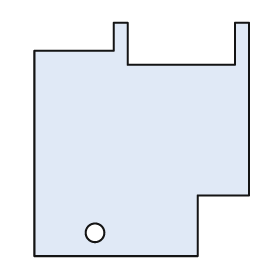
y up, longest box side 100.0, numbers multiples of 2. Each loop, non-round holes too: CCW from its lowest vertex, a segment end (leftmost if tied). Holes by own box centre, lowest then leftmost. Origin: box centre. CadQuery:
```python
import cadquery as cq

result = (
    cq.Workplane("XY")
    .moveTo(-46.0, -50.0)
    .lineTo(24.0, -50.0)
    .lineTo(24.0, -24.0)
    .lineTo(46.0, -24.0)
    .lineTo(46.0, 50.0)
    .lineTo(40.0, 50.0)
    .lineTo(40.0, 32.0)
    .lineTo(-6.0, 32.0)
    .lineTo(-6.0, 50.0)
    .lineTo(-12.0, 50.0)
    .lineTo(-12.0, 38.0)
    .lineTo(-46.0, 38.0)
    .close()
    .moveTo(-20.0, -40.0)
    .circle(4.0)
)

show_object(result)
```